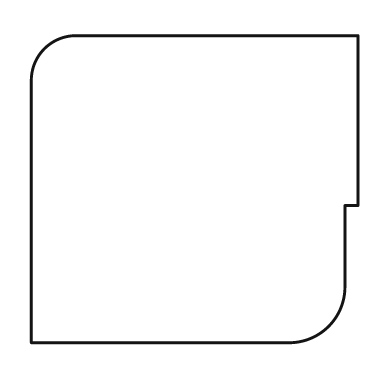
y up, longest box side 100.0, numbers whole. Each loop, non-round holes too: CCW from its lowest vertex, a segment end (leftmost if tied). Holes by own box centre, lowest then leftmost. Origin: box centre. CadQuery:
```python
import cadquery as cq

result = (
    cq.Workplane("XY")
    .moveTo(-50.0, -47.0)
    .lineTo(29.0, -47.0)
    .threePointArc((41.0, -42.0), (46.0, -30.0))
    .lineTo(46.0, -5.0)
    .lineTo(50.0, -5.0)
    .lineTo(50.0, 47.0)
    .lineTo(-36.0, 47.0)
    .threePointArc((-46.0, 43.0), (-50.0, 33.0))
    .close()
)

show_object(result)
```